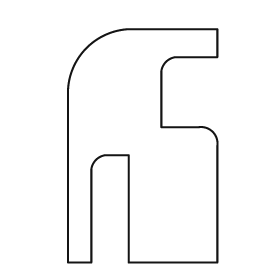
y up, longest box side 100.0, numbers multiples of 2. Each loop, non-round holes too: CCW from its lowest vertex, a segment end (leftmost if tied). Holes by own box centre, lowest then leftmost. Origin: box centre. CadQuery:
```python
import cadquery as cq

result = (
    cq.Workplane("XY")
    .moveTo(-32.0, -50.0)
    .lineTo(-22.0, -50.0)
    .lineTo(-22.0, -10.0)
    .threePointArc((-20.0, -6.0), (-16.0, -4.0))
    .lineTo(-6.0, -4.0)
    .lineTo(-6.0, -50.0)
    .lineTo(32.0, -50.0)
    .lineTo(32.0, 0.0)
    .threePointArc((30.0, 6.0), (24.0, 8.0))
    .lineTo(8.0, 8.0)
    .lineTo(8.0, 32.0)
    .threePointArc((10.0, 36.0), (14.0, 38.0))
    .lineTo(32.0, 38.0)
    .lineTo(32.0, 50.0)
    .lineTo(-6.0, 50.0)
    .threePointArc((-24.0, 42.0), (-32.0, 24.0))
    .close()
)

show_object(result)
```